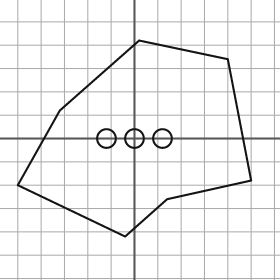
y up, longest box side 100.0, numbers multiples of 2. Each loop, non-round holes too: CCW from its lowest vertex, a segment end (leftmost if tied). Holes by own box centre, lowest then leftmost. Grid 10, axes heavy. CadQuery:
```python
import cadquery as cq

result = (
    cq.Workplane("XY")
    .moveTo(-4.0, -42.0)
    .lineTo(14.0, -26.0)
    .lineTo(50.0, -18.0)
    .lineTo(40.0, 34.0)
    .lineTo(2.0, 42.0)
    .lineTo(-32.0, 12.0)
    .lineTo(-50.0, -20.0)
    .close()
    .moveTo(-12.0, 0.0)
    .circle(4.0)
    .moveTo(0.0, 0.0)
    .circle(4.0)
    .moveTo(12.0, 0.0)
    .circle(4.0)
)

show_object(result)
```